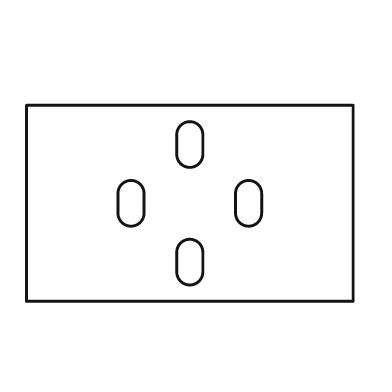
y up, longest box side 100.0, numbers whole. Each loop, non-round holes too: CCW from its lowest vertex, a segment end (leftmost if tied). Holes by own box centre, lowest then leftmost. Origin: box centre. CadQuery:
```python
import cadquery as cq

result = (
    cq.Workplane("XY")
    .moveTo(-50.0, -30.0)
    .lineTo(50.0, -30.0)
    .lineTo(50.0, 30.0)
    .lineTo(-50.0, 30.0)
    .close()
    .moveTo(-4.0, -21.0)
    .threePointArc((0.0, -25.0), (4.0, -21.0))
    .lineTo(4.0, -15.0)
    .threePointArc((0.0, -11.0), (-4.0, -15.0))
    .close()
    .moveTo(-22.0, -3.0)
    .threePointArc((-18.0, -7.0), (-14.0, -3.0))
    .lineTo(-14.0, 3.0)
    .threePointArc((-18.0, 7.0), (-22.0, 3.0))
    .close()
    .moveTo(14.0, -3.0)
    .threePointArc((18.0, -7.0), (22.0, -3.0))
    .lineTo(22.0, 3.0)
    .threePointArc((18.0, 7.0), (14.0, 3.0))
    .close()
    .moveTo(-4.0, 15.0)
    .threePointArc((0.0, 11.0), (4.0, 15.0))
    .lineTo(4.0, 21.0)
    .threePointArc((0.0, 25.0), (-4.0, 21.0))
    .close()
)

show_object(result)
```